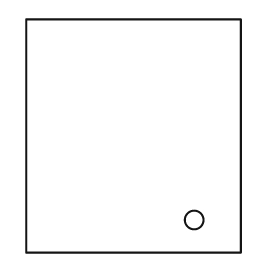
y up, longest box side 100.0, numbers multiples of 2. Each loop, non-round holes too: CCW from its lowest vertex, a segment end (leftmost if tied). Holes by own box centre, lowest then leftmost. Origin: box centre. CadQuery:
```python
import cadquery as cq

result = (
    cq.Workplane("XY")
    .moveTo(-46.0, -50.0)
    .lineTo(46.0, -50.0)
    .lineTo(46.0, 50.0)
    .lineTo(-46.0, 50.0)
    .close()
    .moveTo(26.0, -36.0)
    .circle(4.0)
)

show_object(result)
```